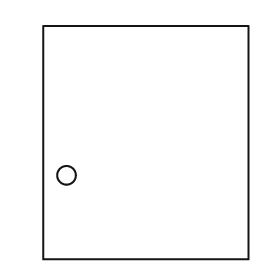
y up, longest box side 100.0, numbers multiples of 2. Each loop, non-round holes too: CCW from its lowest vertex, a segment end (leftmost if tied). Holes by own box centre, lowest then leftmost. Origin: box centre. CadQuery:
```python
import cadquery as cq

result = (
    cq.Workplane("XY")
    .moveTo(-44.0, -50.0)
    .lineTo(44.0, -50.0)
    .lineTo(44.0, 50.0)
    .lineTo(-44.0, 50.0)
    .close()
    .moveTo(-34.0, -14.0)
    .circle(4.0)
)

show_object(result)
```